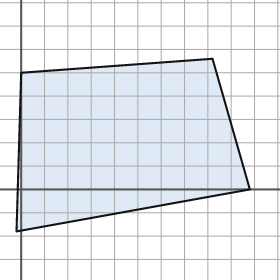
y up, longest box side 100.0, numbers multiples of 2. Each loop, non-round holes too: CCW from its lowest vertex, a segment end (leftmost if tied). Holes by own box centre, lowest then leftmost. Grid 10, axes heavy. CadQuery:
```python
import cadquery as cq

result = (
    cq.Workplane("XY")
    .moveTo(-2.0, -18.0)
    .lineTo(98.0, 0.0)
    .lineTo(82.0, 56.0)
    .lineTo(0.0, 50.0)
    .close()
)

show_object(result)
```